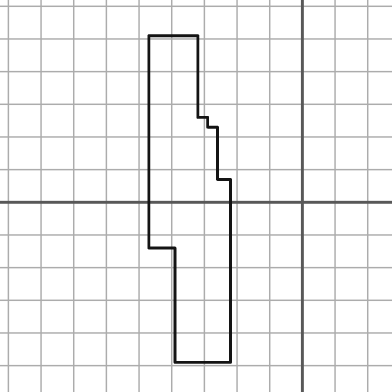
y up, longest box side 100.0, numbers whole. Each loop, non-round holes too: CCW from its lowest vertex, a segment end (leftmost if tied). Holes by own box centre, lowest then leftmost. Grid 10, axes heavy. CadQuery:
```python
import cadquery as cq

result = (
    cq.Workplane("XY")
    .moveTo(-39.0, -49.0)
    .lineTo(-22.0, -49.0)
    .lineTo(-22.0, 7.0)
    .lineTo(-26.0, 7.0)
    .lineTo(-26.0, 23.0)
    .lineTo(-29.0, 23.0)
    .lineTo(-29.0, 26.0)
    .lineTo(-32.0, 26.0)
    .lineTo(-32.0, 51.0)
    .lineTo(-47.0, 51.0)
    .lineTo(-47.0, -14.0)
    .lineTo(-39.0, -14.0)
    .close()
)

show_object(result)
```